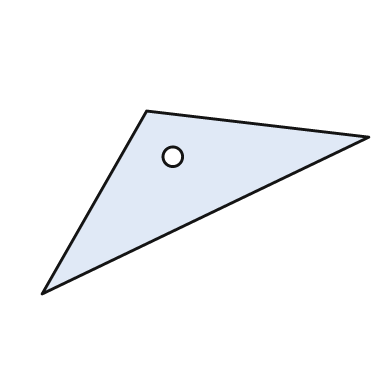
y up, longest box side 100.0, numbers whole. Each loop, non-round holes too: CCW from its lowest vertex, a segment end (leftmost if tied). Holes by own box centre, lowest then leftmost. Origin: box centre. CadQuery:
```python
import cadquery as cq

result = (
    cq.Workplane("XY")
    .moveTo(-50.0, -28.0)
    .lineTo(50.0, 20.0)
    .lineTo(-18.0, 28.0)
    .close()
    .moveTo(-10.0, 14.0)
    .circle(3.0)
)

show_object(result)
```